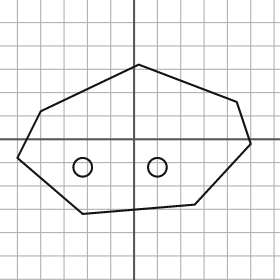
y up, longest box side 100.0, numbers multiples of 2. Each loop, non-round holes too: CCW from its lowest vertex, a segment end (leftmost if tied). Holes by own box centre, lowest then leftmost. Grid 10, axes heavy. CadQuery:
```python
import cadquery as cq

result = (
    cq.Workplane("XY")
    .moveTo(-22.0, -32.0)
    .lineTo(26.0, -28.0)
    .lineTo(50.0, -2.0)
    .lineTo(44.0, 16.0)
    .lineTo(2.0, 32.0)
    .lineTo(-40.0, 12.0)
    .lineTo(-50.0, -8.0)
    .close()
    .moveTo(-22.0, -12.0)
    .circle(4.0)
    .moveTo(10.0, -12.0)
    .circle(4.0)
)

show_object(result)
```